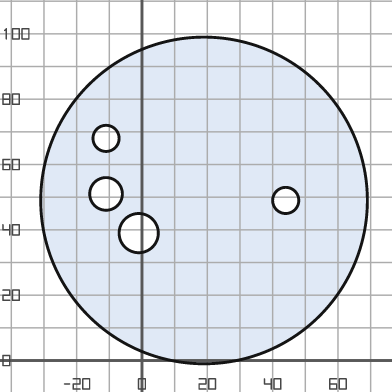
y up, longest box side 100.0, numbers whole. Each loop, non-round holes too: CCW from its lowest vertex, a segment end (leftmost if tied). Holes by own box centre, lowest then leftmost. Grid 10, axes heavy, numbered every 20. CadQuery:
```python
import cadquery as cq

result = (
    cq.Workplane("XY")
    .moveTo(19.0, 49.0)
    .circle(50.0)
    .moveTo(-1.0, 39.0)
    .circle(6.0)
    .moveTo(44.0, 49.0)
    .circle(4.0)
    .moveTo(-11.0, 51.0)
    .circle(5.0)
    .moveTo(-11.0, 68.0)
    .circle(4.0)
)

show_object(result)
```